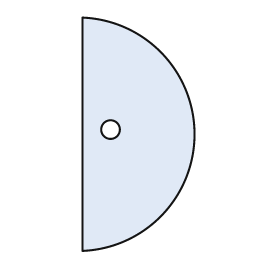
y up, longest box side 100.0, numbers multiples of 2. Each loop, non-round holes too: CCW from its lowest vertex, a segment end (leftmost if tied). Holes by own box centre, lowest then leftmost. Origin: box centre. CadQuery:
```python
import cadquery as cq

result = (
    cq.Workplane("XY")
    .moveTo(-24.0, -50.0)
    .threePointArc((24.0, 0.0), (-24.0, 50.0))
    .close()
    .moveTo(-12.0, 2.0)
    .circle(4.0)
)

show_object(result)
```